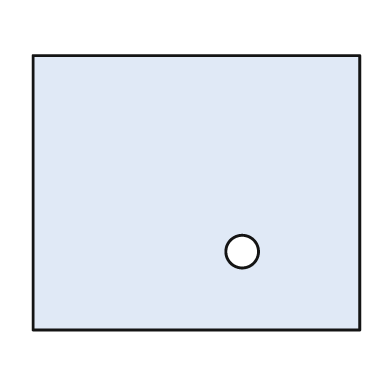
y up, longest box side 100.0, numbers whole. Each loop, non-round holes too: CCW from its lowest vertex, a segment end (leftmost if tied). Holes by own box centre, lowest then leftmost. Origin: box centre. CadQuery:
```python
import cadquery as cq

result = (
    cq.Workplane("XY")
    .moveTo(-50.0, -42.0)
    .lineTo(50.0, -42.0)
    .lineTo(50.0, 42.0)
    .lineTo(-50.0, 42.0)
    .close()
    .moveTo(14.0, -18.0)
    .circle(5.0)
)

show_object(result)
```